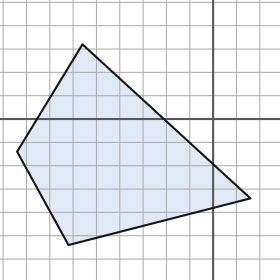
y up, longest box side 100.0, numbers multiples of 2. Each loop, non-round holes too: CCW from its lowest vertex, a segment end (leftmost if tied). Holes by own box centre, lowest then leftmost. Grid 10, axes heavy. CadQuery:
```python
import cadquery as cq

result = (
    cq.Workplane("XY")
    .moveTo(-62.0, -54.0)
    .lineTo(16.0, -34.0)
    .lineTo(-56.0, 32.0)
    .lineTo(-84.0, -14.0)
    .close()
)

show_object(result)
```